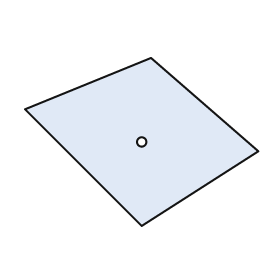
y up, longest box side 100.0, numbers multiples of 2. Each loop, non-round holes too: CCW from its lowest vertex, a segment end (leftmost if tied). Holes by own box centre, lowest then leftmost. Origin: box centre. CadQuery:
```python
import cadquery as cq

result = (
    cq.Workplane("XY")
    .moveTo(0.0, -36.0)
    .lineTo(50.0, -4.0)
    .lineTo(4.0, 36.0)
    .lineTo(-50.0, 14.0)
    .close()
    .moveTo(0.0, 0.0)
    .circle(2.0)
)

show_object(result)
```